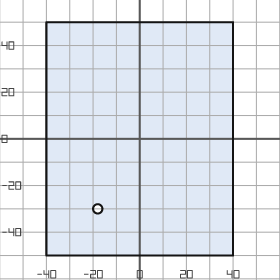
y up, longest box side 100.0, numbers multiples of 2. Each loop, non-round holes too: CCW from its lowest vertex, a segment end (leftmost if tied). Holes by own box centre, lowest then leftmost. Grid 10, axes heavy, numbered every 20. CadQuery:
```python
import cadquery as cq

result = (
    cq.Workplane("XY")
    .moveTo(-40.0, -50.0)
    .lineTo(40.0, -50.0)
    .lineTo(40.0, 50.0)
    .lineTo(-40.0, 50.0)
    .close()
    .moveTo(-18.0, -30.0)
    .circle(2.0)
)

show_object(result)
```